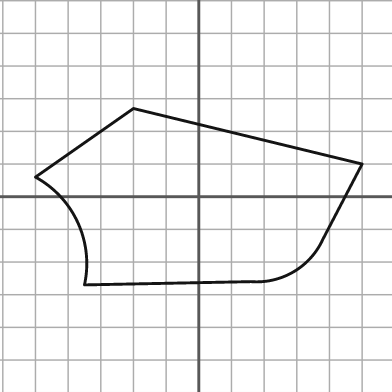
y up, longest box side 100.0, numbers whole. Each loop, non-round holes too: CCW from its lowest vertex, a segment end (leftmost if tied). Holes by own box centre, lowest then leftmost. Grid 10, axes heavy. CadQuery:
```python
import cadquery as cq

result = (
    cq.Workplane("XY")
    .moveTo(-35.0, -27.0)
    .lineTo(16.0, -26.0)
    .threePointArc((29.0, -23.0), (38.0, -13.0))
    .lineTo(50.0, 10.0)
    .lineTo(-20.0, 27.0)
    .lineTo(-50.0, 6.0)
    .threePointArc((-37.0, -8.0), (-35.0, -27.0))
    .close()
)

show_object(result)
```